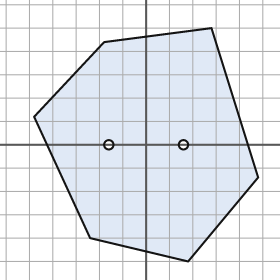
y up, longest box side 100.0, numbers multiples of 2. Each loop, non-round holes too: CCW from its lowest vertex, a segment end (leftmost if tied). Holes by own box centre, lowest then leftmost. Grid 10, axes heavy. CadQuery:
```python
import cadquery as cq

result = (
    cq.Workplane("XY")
    .moveTo(18.0, -50.0)
    .lineTo(48.0, -14.0)
    .lineTo(28.0, 50.0)
    .lineTo(-18.0, 44.0)
    .lineTo(-48.0, 12.0)
    .lineTo(-24.0, -40.0)
    .close()
    .moveTo(-16.0, 0.0)
    .circle(2.0)
    .moveTo(16.0, 0.0)
    .circle(2.0)
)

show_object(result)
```